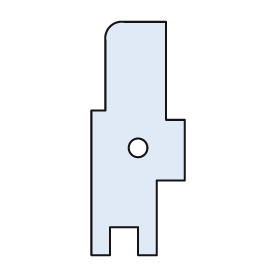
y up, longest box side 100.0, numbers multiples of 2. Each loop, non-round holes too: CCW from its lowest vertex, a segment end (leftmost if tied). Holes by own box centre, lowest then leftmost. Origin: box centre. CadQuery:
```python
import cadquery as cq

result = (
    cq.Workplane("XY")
    .moveTo(-20.0, -50.0)
    .lineTo(-12.0, -50.0)
    .lineTo(-12.0, -38.0)
    .lineTo(0.0, -38.0)
    .lineTo(0.0, -50.0)
    .lineTo(8.0, -50.0)
    .lineTo(8.0, -18.0)
    .lineTo(20.0, -18.0)
    .lineTo(20.0, 8.0)
    .lineTo(12.0, 8.0)
    .lineTo(12.0, 50.0)
    .lineTo(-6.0, 50.0)
    .threePointArc((-12.0, 48.0), (-14.0, 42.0))
    .lineTo(-14.0, 12.0)
    .lineTo(-20.0, 12.0)
    .close()
    .moveTo(0.0, -4.0)
    .circle(4.0)
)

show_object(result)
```